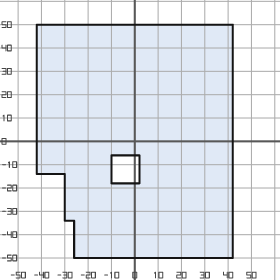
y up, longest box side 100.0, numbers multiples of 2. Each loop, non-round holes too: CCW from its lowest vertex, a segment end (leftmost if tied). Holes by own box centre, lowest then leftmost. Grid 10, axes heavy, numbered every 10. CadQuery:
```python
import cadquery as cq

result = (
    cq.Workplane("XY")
    .moveTo(-26.0, -50.0)
    .lineTo(42.0, -50.0)
    .lineTo(42.0, 50.0)
    .lineTo(-42.0, 50.0)
    .lineTo(-42.0, -14.0)
    .lineTo(-30.0, -14.0)
    .lineTo(-30.0, -34.0)
    .lineTo(-26.0, -34.0)
    .close()
    .moveTo(-10.0, -18.0)
    .lineTo(2.0, -18.0)
    .lineTo(2.0, -6.0)
    .lineTo(-10.0, -6.0)
    .close()
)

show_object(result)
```